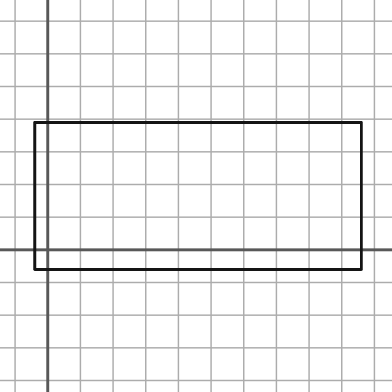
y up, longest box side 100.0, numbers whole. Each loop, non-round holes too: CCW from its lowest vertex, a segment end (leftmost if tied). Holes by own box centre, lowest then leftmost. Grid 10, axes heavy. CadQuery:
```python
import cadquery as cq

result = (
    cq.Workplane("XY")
    .moveTo(-4.0, -6.0)
    .lineTo(96.0, -6.0)
    .lineTo(96.0, 39.0)
    .lineTo(-4.0, 39.0)
    .close()
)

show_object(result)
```